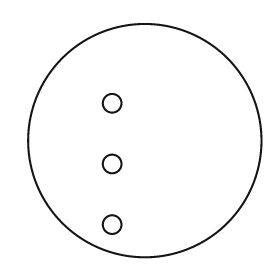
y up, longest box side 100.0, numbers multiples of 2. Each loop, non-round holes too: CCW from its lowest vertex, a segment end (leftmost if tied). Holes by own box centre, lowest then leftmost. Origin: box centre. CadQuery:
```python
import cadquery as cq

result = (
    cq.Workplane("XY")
    .moveTo(0.0, 0.0)
    .circle(50.0)
    .moveTo(-14.0, -36.0)
    .circle(4.0)
    .moveTo(-14.0, -10.0)
    .circle(4.0)
    .moveTo(-14.0, 16.0)
    .circle(4.0)
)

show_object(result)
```